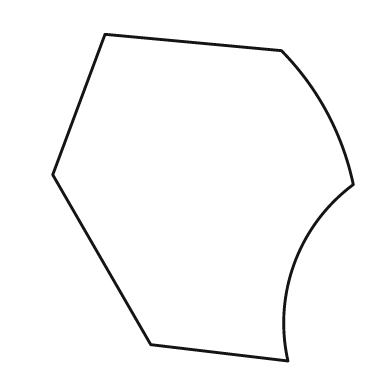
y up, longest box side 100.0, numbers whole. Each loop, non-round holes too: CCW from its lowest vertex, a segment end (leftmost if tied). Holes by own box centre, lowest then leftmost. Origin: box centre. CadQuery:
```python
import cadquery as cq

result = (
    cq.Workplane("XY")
    .moveTo(26.0, -50.0)
    .threePointArc((28.0, -20.0), (46.0, 4.0))
    .threePointArc((38.0, 26.0), (24.0, 45.0))
    .lineTo(-30.0, 50.0)
    .lineTo(-46.0, 7.0)
    .lineTo(-16.0, -45.0)
    .close()
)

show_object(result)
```